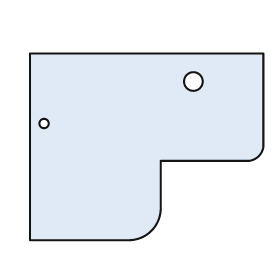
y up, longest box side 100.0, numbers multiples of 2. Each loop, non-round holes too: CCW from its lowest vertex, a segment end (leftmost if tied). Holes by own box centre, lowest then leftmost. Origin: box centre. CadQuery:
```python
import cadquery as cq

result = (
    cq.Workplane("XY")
    .moveTo(-50.0, -40.0)
    .lineTo(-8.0, -40.0)
    .threePointArc((2.0, -36.0), (6.0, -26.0))
    .lineTo(6.0, -6.0)
    .lineTo(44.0, -6.0)
    .threePointArc((48.0, -4.0), (50.0, 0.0))
    .lineTo(50.0, 40.0)
    .lineTo(-50.0, 40.0)
    .close()
    .moveTo(-44.0, 10.0)
    .circle(2.0)
    .moveTo(20.0, 28.0)
    .circle(4.0)
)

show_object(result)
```